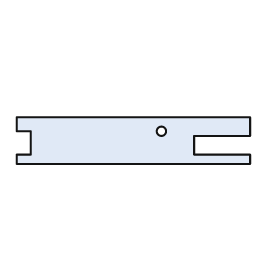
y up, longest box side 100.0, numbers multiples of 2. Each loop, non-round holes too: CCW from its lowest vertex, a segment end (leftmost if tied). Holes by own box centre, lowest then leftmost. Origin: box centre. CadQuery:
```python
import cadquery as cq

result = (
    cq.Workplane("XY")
    .moveTo(-50.0, -10.0)
    .lineTo(50.0, -10.0)
    .lineTo(50.0, -6.0)
    .lineTo(26.0, -6.0)
    .lineTo(26.0, 2.0)
    .lineTo(50.0, 2.0)
    .lineTo(50.0, 10.0)
    .lineTo(-50.0, 10.0)
    .lineTo(-50.0, 4.0)
    .lineTo(-44.0, 4.0)
    .lineTo(-44.0, -6.0)
    .lineTo(-50.0, -6.0)
    .close()
    .moveTo(12.0, 4.0)
    .circle(2.0)
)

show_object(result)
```